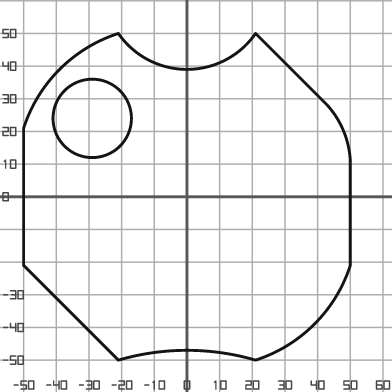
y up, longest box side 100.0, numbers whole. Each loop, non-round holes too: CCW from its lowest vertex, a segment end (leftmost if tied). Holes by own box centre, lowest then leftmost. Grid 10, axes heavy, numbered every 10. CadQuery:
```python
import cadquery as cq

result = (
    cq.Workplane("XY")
    .moveTo(-21.0, -50.0)
    .threePointArc((0.0, -47.0), (21.0, -50.0))
    .threePointArc((39.0, -39.0), (50.0, -21.0))
    .lineTo(50.0, 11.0)
    .threePointArc((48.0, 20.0), (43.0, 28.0))
    .lineTo(21.0, 50.0)
    .threePointArc((0.0, 39.0), (-21.0, 50.0))
    .threePointArc((-39.0, 39.0), (-50.0, 21.0))
    .lineTo(-50.0, -21.0)
    .close()
    .moveTo(-29.0, 24.0)
    .circle(12.0)
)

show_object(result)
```